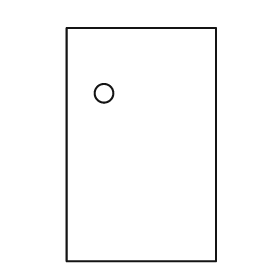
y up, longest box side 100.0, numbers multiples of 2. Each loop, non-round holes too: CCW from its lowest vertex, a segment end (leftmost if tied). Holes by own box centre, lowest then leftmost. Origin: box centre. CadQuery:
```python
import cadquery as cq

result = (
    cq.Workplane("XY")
    .moveTo(-32.0, -50.0)
    .lineTo(32.0, -50.0)
    .lineTo(32.0, 50.0)
    .lineTo(-32.0, 50.0)
    .close()
    .moveTo(-16.0, 22.0)
    .circle(4.0)
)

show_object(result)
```